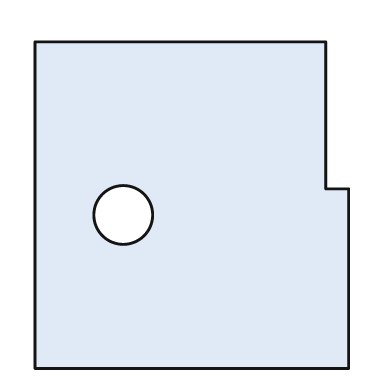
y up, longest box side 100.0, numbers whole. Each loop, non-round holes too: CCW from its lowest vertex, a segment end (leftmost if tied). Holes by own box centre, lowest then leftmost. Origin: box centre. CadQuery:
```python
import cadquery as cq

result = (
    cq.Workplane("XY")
    .moveTo(-48.0, -50.0)
    .lineTo(48.0, -50.0)
    .lineTo(48.0, 5.0)
    .lineTo(41.0, 5.0)
    .lineTo(41.0, 50.0)
    .lineTo(-48.0, 50.0)
    .close()
    .moveTo(-21.0, -3.0)
    .circle(9.0)
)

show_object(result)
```